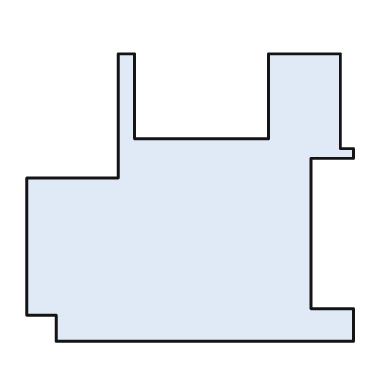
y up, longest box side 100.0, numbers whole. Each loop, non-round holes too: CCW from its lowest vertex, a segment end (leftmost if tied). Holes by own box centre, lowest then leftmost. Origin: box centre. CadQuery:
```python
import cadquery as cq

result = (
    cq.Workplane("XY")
    .moveTo(-41.0, -44.0)
    .lineTo(50.0, -44.0)
    .lineTo(50.0, -34.0)
    .lineTo(37.0, -34.0)
    .lineTo(37.0, 12.0)
    .lineTo(50.0, 12.0)
    .lineTo(50.0, 15.0)
    .lineTo(46.0, 15.0)
    .lineTo(46.0, 44.0)
    .lineTo(24.0, 44.0)
    .lineTo(24.0, 18.0)
    .lineTo(-17.0, 18.0)
    .lineTo(-17.0, 44.0)
    .lineTo(-22.0, 44.0)
    .lineTo(-22.0, 6.0)
    .lineTo(-50.0, 6.0)
    .lineTo(-50.0, -36.0)
    .lineTo(-41.0, -36.0)
    .close()
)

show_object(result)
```